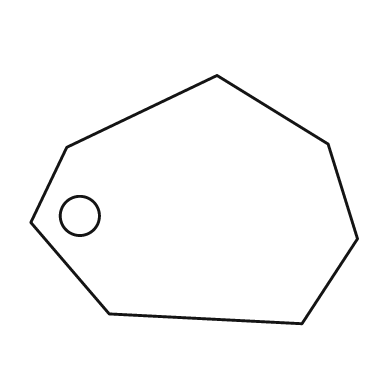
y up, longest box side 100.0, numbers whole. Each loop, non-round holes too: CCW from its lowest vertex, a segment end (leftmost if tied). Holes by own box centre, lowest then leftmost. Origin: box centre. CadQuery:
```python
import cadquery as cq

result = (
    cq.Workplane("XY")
    .moveTo(33.0, -38.0)
    .lineTo(50.0, -12.0)
    .lineTo(41.0, 17.0)
    .lineTo(7.0, 38.0)
    .lineTo(-39.0, 16.0)
    .lineTo(-50.0, -7.0)
    .lineTo(-26.0, -35.0)
    .close()
    .moveTo(-35.0, -5.0)
    .circle(6.0)
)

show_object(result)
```